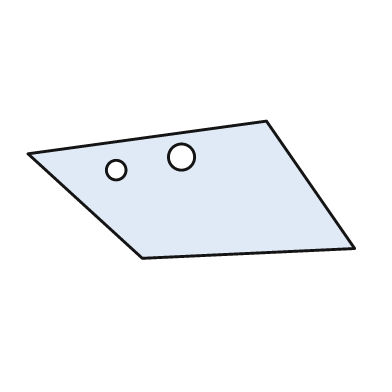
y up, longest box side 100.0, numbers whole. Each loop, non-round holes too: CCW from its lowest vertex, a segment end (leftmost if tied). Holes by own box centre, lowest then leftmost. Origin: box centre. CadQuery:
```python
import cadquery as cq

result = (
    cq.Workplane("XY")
    .moveTo(-15.0, -21.0)
    .lineTo(50.0, -18.0)
    .lineTo(23.0, 21.0)
    .lineTo(-50.0, 11.0)
    .close()
    .moveTo(-23.0, 6.0)
    .circle(3.0)
    .moveTo(-3.0, 10.0)
    .circle(4.0)
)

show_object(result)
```